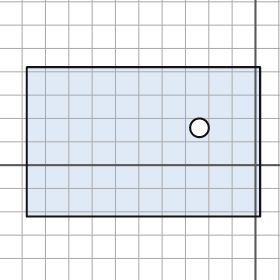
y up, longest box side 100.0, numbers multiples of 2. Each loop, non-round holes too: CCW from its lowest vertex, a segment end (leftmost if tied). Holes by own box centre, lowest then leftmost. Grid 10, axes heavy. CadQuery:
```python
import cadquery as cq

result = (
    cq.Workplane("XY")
    .moveTo(-98.0, -22.0)
    .lineTo(2.0, -22.0)
    .lineTo(2.0, 42.0)
    .lineTo(-98.0, 42.0)
    .close()
    .moveTo(-24.0, 16.0)
    .circle(4.0)
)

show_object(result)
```